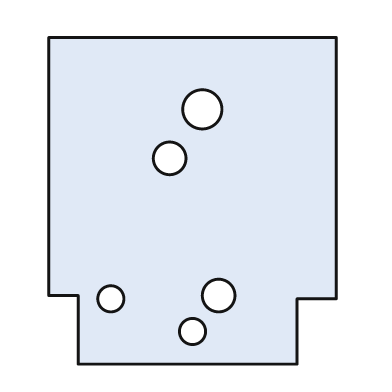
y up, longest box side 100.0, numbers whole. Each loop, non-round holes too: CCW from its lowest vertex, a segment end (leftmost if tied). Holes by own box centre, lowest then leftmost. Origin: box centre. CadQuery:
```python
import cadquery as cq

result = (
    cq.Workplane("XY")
    .moveTo(-35.0, -50.0)
    .lineTo(32.0, -50.0)
    .lineTo(32.0, -30.0)
    .lineTo(44.0, -30.0)
    .lineTo(44.0, 50.0)
    .lineTo(-44.0, 50.0)
    .lineTo(-44.0, -29.0)
    .lineTo(-35.0, -29.0)
    .close()
    .moveTo(0.0, -40.0)
    .circle(4.0)
    .moveTo(-25.0, -30.0)
    .circle(4.0)
    .moveTo(8.0, -29.0)
    .circle(5.0)
    .moveTo(-7.0, 13.0)
    .circle(5.0)
    .moveTo(3.0, 28.0)
    .circle(6.0)
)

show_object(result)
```